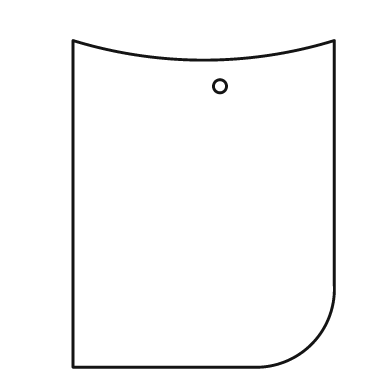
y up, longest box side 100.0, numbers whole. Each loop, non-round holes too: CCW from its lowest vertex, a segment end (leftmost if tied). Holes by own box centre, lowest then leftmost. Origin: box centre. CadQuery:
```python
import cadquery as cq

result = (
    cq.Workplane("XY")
    .moveTo(-40.0, -50.0)
    .lineTo(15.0, -50.0)
    .threePointArc((33.0, -43.0), (40.0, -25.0))
    .lineTo(40.0, 50.0)
    .threePointArc((0.0, 44.0), (-40.0, 50.0))
    .close()
    .moveTo(5.0, 36.0)
    .circle(2.0)
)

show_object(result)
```